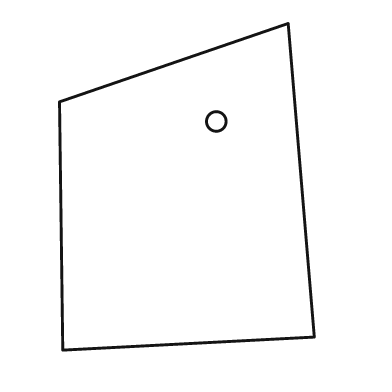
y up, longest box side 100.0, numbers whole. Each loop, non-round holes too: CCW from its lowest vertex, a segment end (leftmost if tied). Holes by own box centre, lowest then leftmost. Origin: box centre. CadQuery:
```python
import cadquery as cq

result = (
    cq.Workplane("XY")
    .moveTo(-38.0, -50.0)
    .lineTo(39.0, -46.0)
    .lineTo(31.0, 50.0)
    .lineTo(-39.0, 26.0)
    .close()
    .moveTo(9.0, 20.0)
    .circle(3.0)
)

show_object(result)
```